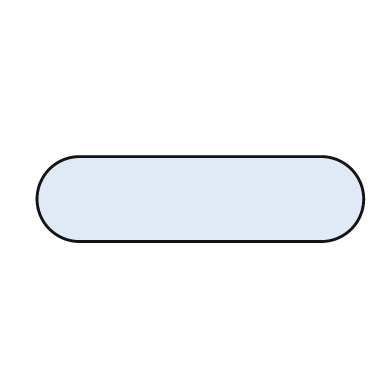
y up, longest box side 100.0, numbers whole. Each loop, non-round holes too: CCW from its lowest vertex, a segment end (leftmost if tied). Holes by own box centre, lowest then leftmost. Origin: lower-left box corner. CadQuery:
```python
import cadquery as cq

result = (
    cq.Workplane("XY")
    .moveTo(13.0, 0.0)
    .lineTo(87.0, 0.0)
    .threePointArc((100.0, 13.0), (87.0, 26.0))
    .lineTo(13.0, 26.0)
    .threePointArc((0.0, 13.0), (13.0, 0.0))
    .close()
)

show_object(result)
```